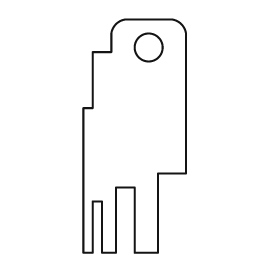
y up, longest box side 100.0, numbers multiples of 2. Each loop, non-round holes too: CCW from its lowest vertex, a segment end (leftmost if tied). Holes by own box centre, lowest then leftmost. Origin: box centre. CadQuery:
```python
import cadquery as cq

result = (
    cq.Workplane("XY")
    .moveTo(-22.0, -50.0)
    .lineTo(-18.0, -50.0)
    .lineTo(-18.0, -28.0)
    .lineTo(-14.0, -28.0)
    .lineTo(-14.0, -50.0)
    .lineTo(-8.0, -50.0)
    .lineTo(-8.0, -22.0)
    .lineTo(0.0, -22.0)
    .lineTo(0.0, -50.0)
    .lineTo(10.0, -50.0)
    .lineTo(10.0, -16.0)
    .lineTo(22.0, -16.0)
    .lineTo(22.0, 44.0)
    .threePointArc((20.0, 48.0), (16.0, 50.0))
    .lineTo(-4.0, 50.0)
    .threePointArc((-8.0, 48.0), (-10.0, 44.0))
    .lineTo(-10.0, 36.0)
    .lineTo(-18.0, 36.0)
    .lineTo(-18.0, 12.0)
    .lineTo(-22.0, 12.0)
    .close()
    .moveTo(6.0, 38.0)
    .circle(6.0)
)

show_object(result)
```